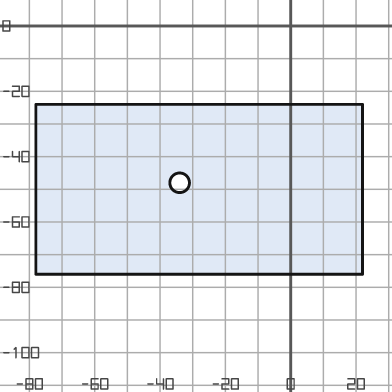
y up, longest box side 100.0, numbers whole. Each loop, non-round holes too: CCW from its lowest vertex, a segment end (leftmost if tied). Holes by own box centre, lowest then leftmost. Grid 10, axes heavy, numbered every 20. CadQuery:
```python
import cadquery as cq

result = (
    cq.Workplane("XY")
    .moveTo(-78.0, -76.0)
    .lineTo(22.0, -76.0)
    .lineTo(22.0, -24.0)
    .lineTo(-78.0, -24.0)
    .close()
    .moveTo(-34.0, -48.0)
    .circle(3.0)
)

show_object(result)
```